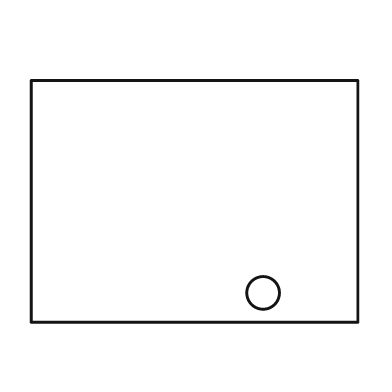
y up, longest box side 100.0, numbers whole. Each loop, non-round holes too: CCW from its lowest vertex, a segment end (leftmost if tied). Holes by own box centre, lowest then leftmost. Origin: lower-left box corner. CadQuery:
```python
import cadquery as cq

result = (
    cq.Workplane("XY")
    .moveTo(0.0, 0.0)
    .lineTo(100.0, 0.0)
    .lineTo(100.0, 74.0)
    .lineTo(0.0, 74.0)
    .close()
    .moveTo(71.0, 9.0)
    .circle(5.0)
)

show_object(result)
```